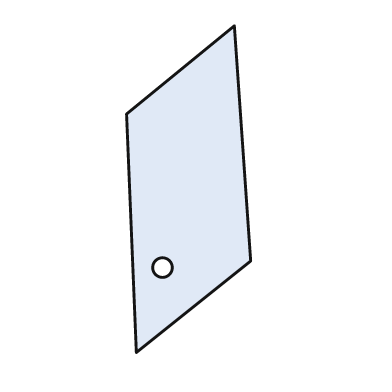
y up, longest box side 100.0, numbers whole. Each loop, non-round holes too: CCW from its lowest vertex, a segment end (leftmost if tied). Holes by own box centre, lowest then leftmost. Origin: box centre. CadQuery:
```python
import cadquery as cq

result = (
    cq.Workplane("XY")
    .moveTo(-16.0, -50.0)
    .lineTo(19.0, -22.0)
    .lineTo(14.0, 50.0)
    .lineTo(-19.0, 23.0)
    .close()
    .moveTo(-8.0, -24.0)
    .circle(3.0)
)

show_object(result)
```